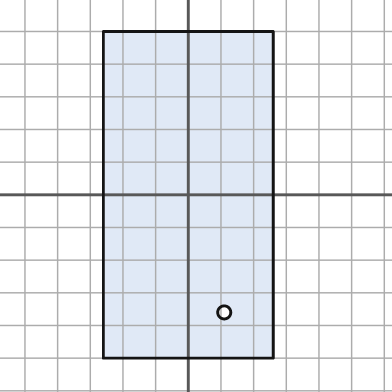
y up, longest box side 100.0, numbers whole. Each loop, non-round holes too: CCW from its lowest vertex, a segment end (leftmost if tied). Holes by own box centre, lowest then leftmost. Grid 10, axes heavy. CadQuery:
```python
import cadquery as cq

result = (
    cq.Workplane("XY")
    .moveTo(-26.0, -50.0)
    .lineTo(26.0, -50.0)
    .lineTo(26.0, 50.0)
    .lineTo(-26.0, 50.0)
    .close()
    .moveTo(11.0, -36.0)
    .circle(2.0)
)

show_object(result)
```